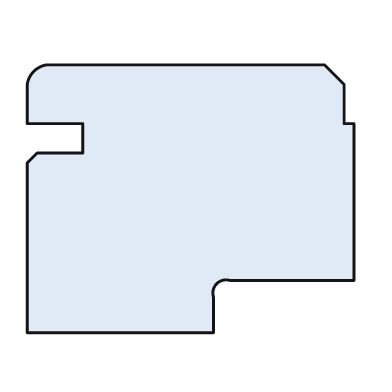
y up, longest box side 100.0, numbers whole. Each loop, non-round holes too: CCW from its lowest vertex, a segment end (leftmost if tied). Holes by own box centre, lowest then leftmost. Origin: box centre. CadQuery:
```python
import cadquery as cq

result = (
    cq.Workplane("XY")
    .moveTo(-50.0, -41.0)
    .lineTo(7.0, -41.0)
    .lineTo(7.0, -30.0)
    .threePointArc((8.0, -26.0), (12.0, -25.0))
    .lineTo(50.0, -25.0)
    .lineTo(50.0, 23.0)
    .lineTo(47.0, 23.0)
    .lineTo(47.0, 35.0)
    .lineTo(41.0, 41.0)
    .lineTo(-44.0, 41.0)
    .threePointArc((-48.0, 39.0), (-50.0, 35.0))
    .lineTo(-50.0, 23.0)
    .lineTo(-33.0, 23.0)
    .lineTo(-33.0, 14.0)
    .lineTo(-47.0, 14.0)
    .lineTo(-50.0, 11.0)
    .close()
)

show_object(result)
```